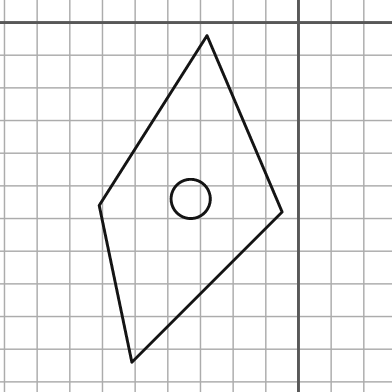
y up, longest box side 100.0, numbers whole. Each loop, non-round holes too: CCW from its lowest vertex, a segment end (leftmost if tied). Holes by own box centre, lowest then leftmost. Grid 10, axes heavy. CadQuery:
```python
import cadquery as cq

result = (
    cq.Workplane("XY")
    .moveTo(-51.0, -104.0)
    .lineTo(-5.0, -58.0)
    .lineTo(-28.0, -4.0)
    .lineTo(-61.0, -56.0)
    .close()
    .moveTo(-33.0, -54.0)
    .circle(6.0)
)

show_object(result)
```